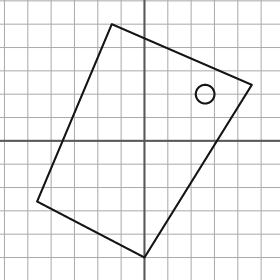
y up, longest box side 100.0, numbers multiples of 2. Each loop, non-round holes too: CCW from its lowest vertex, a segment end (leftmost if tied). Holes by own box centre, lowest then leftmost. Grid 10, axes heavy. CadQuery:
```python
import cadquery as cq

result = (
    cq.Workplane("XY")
    .moveTo(0.0, -50.0)
    .lineTo(46.0, 24.0)
    .lineTo(-14.0, 50.0)
    .lineTo(-46.0, -26.0)
    .close()
    .moveTo(26.0, 20.0)
    .circle(4.0)
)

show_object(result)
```